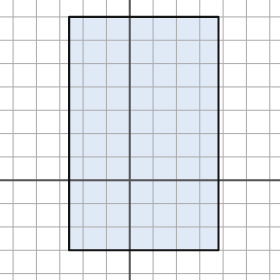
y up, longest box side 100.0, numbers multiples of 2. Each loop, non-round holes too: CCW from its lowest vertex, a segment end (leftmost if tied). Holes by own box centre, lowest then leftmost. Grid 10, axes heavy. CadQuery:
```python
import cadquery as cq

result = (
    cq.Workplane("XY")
    .moveTo(-26.0, -30.0)
    .lineTo(38.0, -30.0)
    .lineTo(38.0, 70.0)
    .lineTo(-26.0, 70.0)
    .close()
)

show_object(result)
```